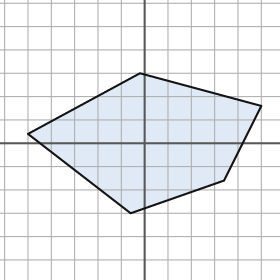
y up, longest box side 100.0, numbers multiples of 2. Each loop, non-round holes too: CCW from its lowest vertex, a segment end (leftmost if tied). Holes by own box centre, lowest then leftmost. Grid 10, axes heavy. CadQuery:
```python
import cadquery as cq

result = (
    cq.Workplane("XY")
    .moveTo(-6.0, -30.0)
    .lineTo(34.0, -16.0)
    .lineTo(50.0, 16.0)
    .lineTo(-2.0, 30.0)
    .lineTo(-50.0, 4.0)
    .close()
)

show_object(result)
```